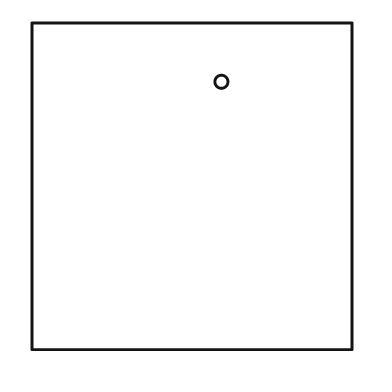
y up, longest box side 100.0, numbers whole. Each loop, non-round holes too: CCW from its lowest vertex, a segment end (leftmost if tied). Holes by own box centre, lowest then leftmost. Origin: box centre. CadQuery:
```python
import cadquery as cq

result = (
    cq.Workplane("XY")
    .moveTo(-49.0, -50.0)
    .lineTo(49.0, -50.0)
    .lineTo(49.0, 50.0)
    .lineTo(-49.0, 50.0)
    .close()
    .moveTo(9.0, 32.0)
    .circle(2.0)
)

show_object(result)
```